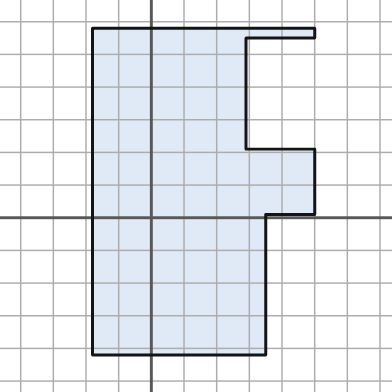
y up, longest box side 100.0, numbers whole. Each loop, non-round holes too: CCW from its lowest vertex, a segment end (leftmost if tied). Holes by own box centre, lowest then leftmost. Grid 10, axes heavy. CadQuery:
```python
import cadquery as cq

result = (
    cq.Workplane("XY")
    .moveTo(-18.0, -42.0)
    .lineTo(35.0, -42.0)
    .lineTo(35.0, 1.0)
    .lineTo(50.0, 1.0)
    .lineTo(50.0, 21.0)
    .lineTo(29.0, 21.0)
    .lineTo(29.0, 55.0)
    .lineTo(50.0, 55.0)
    .lineTo(50.0, 58.0)
    .lineTo(-18.0, 58.0)
    .close()
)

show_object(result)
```